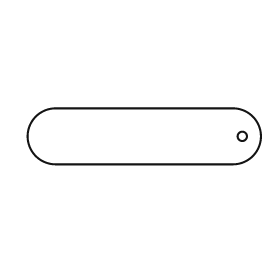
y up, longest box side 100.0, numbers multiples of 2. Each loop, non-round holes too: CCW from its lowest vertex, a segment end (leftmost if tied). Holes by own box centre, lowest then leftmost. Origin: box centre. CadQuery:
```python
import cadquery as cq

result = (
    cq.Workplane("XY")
    .moveTo(-38.0, -12.0)
    .lineTo(38.0, -12.0)
    .threePointArc((50.0, 0.0), (38.0, 12.0))
    .lineTo(-38.0, 12.0)
    .threePointArc((-50.0, 0.0), (-38.0, -12.0))
    .close()
    .moveTo(42.0, 0.0)
    .circle(2.0)
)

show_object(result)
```